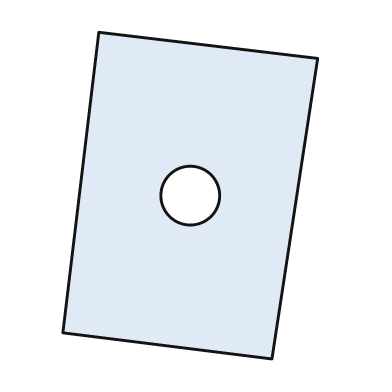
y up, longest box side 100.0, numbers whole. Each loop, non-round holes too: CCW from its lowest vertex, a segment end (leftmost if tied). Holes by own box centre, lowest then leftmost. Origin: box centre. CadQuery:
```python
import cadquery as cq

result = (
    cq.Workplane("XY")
    .moveTo(25.0, -50.0)
    .lineTo(39.0, 42.0)
    .lineTo(-28.0, 50.0)
    .lineTo(-39.0, -42.0)
    .close()
    .moveTo(0.0, 0.0)
    .circle(9.0)
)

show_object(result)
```